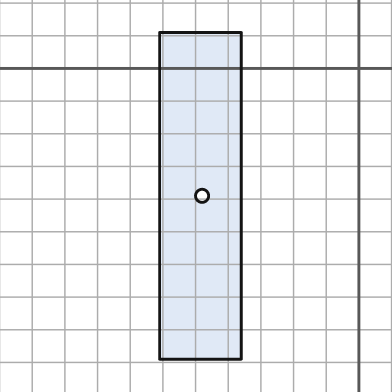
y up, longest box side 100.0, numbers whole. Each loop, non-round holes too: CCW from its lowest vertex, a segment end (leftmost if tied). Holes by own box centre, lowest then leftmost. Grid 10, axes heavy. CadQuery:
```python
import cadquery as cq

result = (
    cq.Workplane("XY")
    .moveTo(-61.0, -89.0)
    .lineTo(-36.0, -89.0)
    .lineTo(-36.0, 11.0)
    .lineTo(-61.0, 11.0)
    .close()
    .moveTo(-48.0, -39.0)
    .circle(2.0)
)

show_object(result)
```